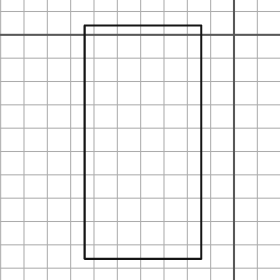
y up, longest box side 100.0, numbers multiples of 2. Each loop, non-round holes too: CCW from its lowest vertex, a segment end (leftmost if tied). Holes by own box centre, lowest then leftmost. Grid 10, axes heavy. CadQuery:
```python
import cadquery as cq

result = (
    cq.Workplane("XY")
    .moveTo(-64.0, -96.0)
    .lineTo(-14.0, -96.0)
    .lineTo(-14.0, 4.0)
    .lineTo(-64.0, 4.0)
    .close()
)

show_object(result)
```